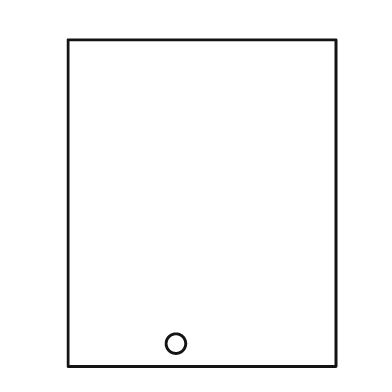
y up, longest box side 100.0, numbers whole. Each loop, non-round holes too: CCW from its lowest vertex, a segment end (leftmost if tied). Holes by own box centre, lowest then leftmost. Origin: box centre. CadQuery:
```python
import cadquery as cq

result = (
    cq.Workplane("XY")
    .moveTo(-41.0, -50.0)
    .lineTo(41.0, -50.0)
    .lineTo(41.0, 50.0)
    .lineTo(-41.0, 50.0)
    .close()
    .moveTo(-8.0, -43.0)
    .circle(3.0)
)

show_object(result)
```